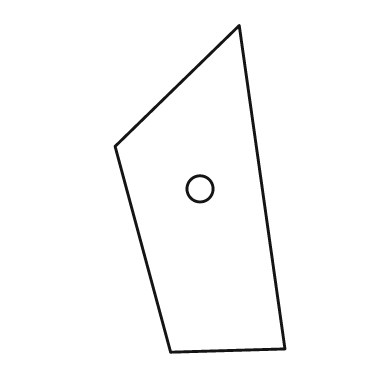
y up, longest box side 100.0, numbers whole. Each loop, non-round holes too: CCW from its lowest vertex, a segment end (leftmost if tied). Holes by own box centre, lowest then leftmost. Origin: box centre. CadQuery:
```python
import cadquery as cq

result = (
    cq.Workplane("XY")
    .moveTo(-9.0, -50.0)
    .lineTo(26.0, -49.0)
    .lineTo(12.0, 50.0)
    .lineTo(-26.0, 13.0)
    .close()
    .moveTo(0.0, 0.0)
    .circle(4.0)
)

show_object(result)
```